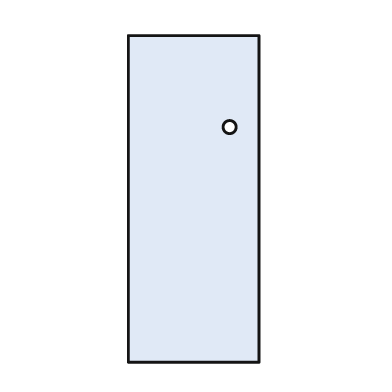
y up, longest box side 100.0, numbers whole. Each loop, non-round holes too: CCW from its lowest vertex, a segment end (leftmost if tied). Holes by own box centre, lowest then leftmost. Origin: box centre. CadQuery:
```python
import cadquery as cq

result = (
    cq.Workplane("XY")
    .moveTo(-20.0, -50.0)
    .lineTo(20.0, -50.0)
    .lineTo(20.0, 50.0)
    .lineTo(-20.0, 50.0)
    .close()
    .moveTo(11.0, 22.0)
    .circle(2.0)
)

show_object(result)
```